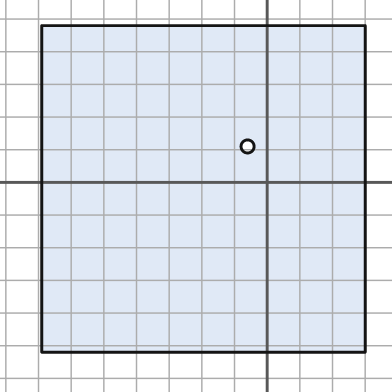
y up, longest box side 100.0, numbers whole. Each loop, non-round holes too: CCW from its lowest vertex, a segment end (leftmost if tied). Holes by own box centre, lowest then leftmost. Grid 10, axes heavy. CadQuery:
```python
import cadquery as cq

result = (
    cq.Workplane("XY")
    .moveTo(-69.0, -52.0)
    .lineTo(30.0, -52.0)
    .lineTo(30.0, 48.0)
    .lineTo(-69.0, 48.0)
    .close()
    .moveTo(-6.0, 11.0)
    .circle(2.0)
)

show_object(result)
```